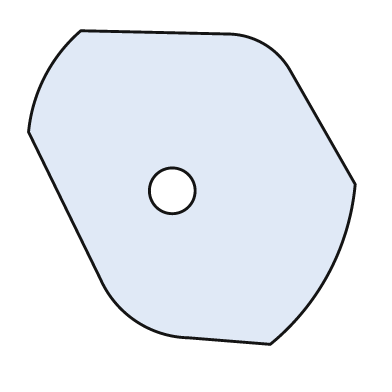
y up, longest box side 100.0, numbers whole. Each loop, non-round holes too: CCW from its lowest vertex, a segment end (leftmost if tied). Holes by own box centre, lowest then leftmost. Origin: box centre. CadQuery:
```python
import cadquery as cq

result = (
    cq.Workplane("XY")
    .moveTo(24.0, -48.0)
    .threePointArc((42.0, -26.0), (50.0, 1.0))
    .lineTo(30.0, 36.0)
    .threePointArc((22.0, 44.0), (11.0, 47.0))
    .lineTo(-34.0, 48.0)
    .threePointArc((-45.0, 34.0), (-50.0, 17.0))
    .lineTo(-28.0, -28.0)
    .threePointArc((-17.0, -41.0), (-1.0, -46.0))
    .close()
    .moveTo(-6.0, -1.0)
    .circle(7.0)
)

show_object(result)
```